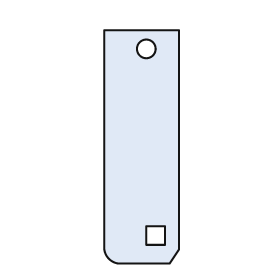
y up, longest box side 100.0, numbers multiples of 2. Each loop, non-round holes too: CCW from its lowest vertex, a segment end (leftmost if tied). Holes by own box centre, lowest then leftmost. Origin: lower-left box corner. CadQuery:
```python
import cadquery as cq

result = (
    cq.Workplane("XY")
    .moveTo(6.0, 0.0)
    .lineTo(28.0, 0.0)
    .lineTo(32.0, 6.0)
    .lineTo(32.0, 100.0)
    .lineTo(0.0, 100.0)
    .lineTo(0.0, 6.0)
    .threePointArc((2.0, 2.0), (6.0, 0.0))
    .close()
    .moveTo(18.0, 8.0)
    .lineTo(26.0, 8.0)
    .lineTo(26.0, 16.0)
    .lineTo(18.0, 16.0)
    .close()
    .moveTo(18.0, 92.0)
    .circle(4.0)
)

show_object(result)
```